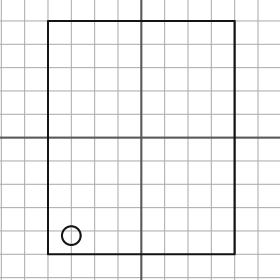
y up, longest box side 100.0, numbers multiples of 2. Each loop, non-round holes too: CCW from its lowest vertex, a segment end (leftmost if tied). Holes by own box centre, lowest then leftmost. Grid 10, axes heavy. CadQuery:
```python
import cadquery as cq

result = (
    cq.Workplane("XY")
    .moveTo(-40.0, -50.0)
    .lineTo(40.0, -50.0)
    .lineTo(40.0, 50.0)
    .lineTo(-40.0, 50.0)
    .close()
    .moveTo(-30.0, -42.0)
    .circle(4.0)
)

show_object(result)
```